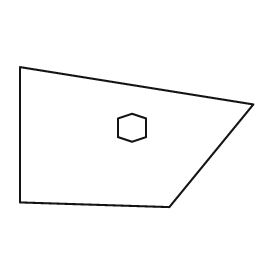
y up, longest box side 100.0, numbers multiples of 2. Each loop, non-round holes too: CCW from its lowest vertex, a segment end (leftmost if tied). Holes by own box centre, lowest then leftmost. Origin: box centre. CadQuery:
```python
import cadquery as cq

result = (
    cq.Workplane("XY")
    .moveTo(14.0, -30.0)
    .lineTo(50.0, 14.0)
    .lineTo(-50.0, 30.0)
    .lineTo(-50.0, -28.0)
    .close()
    .moveTo(-2.0, -2.0)
    .lineTo(4.0, 0.0)
    .lineTo(4.0, 8.0)
    .lineTo(-2.0, 10.0)
    .lineTo(-8.0, 8.0)
    .lineTo(-8.0, 0.0)
    .close()
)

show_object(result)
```